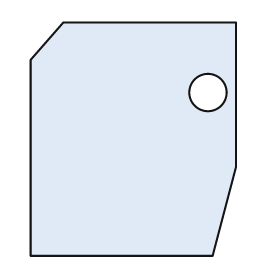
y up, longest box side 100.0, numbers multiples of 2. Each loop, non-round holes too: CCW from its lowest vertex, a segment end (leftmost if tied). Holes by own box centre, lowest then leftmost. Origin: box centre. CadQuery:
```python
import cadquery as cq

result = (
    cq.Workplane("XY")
    .moveTo(-44.0, -50.0)
    .lineTo(34.0, -50.0)
    .lineTo(44.0, -12.0)
    .lineTo(44.0, 50.0)
    .lineTo(-30.0, 50.0)
    .lineTo(-44.0, 34.0)
    .close()
    .moveTo(32.0, 20.0)
    .circle(8.0)
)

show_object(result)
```